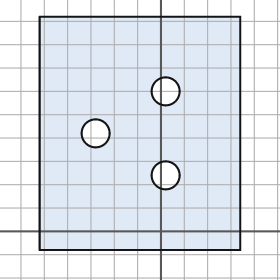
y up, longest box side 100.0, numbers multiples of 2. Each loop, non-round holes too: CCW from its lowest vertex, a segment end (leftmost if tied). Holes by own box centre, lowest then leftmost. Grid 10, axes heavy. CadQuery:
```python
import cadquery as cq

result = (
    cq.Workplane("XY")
    .moveTo(-52.0, -8.0)
    .lineTo(34.0, -8.0)
    .lineTo(34.0, 92.0)
    .lineTo(-52.0, 92.0)
    .close()
    .moveTo(2.0, 24.0)
    .circle(6.0)
    .moveTo(-28.0, 42.0)
    .circle(6.0)
    .moveTo(2.0, 60.0)
    .circle(6.0)
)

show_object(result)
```